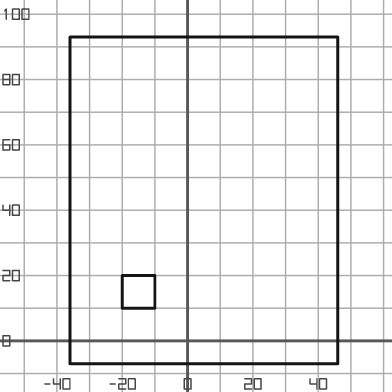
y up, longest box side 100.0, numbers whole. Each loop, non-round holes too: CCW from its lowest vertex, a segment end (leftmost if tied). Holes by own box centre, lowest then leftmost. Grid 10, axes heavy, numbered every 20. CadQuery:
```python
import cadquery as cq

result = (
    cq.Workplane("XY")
    .moveTo(-36.0, -7.0)
    .lineTo(46.0, -7.0)
    .lineTo(46.0, 93.0)
    .lineTo(-36.0, 93.0)
    .close()
    .moveTo(-20.0, 10.0)
    .lineTo(-10.0, 10.0)
    .lineTo(-10.0, 20.0)
    .lineTo(-20.0, 20.0)
    .close()
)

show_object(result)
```